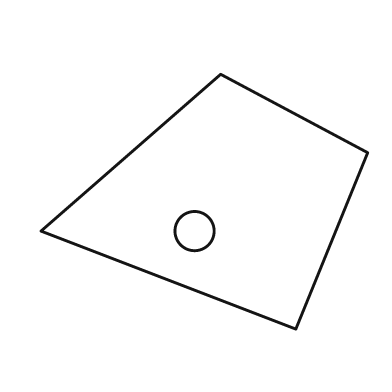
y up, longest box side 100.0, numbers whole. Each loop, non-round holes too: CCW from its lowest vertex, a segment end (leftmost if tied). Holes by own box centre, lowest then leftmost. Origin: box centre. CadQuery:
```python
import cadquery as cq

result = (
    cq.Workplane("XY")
    .moveTo(28.0, -39.0)
    .lineTo(50.0, 15.0)
    .lineTo(5.0, 39.0)
    .lineTo(-50.0, -9.0)
    .close()
    .moveTo(-3.0, -9.0)
    .circle(6.0)
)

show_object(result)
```